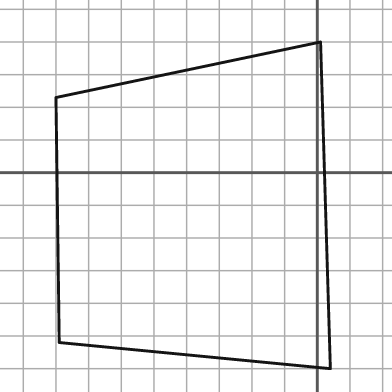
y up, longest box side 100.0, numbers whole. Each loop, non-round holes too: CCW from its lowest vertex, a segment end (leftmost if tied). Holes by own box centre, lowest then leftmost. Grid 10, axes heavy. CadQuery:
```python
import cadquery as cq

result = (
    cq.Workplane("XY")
    .moveTo(4.0, -60.0)
    .lineTo(1.0, 40.0)
    .lineTo(-80.0, 23.0)
    .lineTo(-79.0, -52.0)
    .close()
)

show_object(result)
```